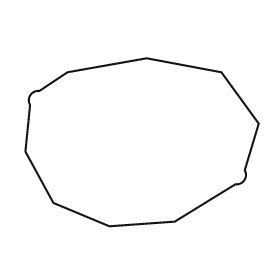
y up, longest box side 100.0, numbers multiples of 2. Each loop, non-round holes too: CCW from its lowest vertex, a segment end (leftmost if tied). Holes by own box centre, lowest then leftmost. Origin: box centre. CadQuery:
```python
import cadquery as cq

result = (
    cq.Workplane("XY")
    .moveTo(-14.0, -36.0)
    .lineTo(14.0, -34.0)
    .lineTo(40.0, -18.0)
    .threePointArc((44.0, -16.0), (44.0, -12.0))
    .lineTo(50.0, 8.0)
    .lineTo(34.0, 30.0)
    .lineTo(2.0, 36.0)
    .lineTo(-32.0, 30.0)
    .lineTo(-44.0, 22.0)
    .threePointArc((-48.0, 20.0), (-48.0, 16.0))
    .lineTo(-50.0, -4.0)
    .lineTo(-38.0, -26.0)
    .close()
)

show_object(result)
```